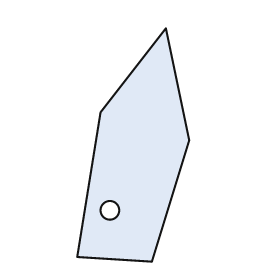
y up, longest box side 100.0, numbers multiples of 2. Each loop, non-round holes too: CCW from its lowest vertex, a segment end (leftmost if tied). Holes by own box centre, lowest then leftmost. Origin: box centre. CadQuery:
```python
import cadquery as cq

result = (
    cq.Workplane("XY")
    .moveTo(8.0, -50.0)
    .lineTo(24.0, 2.0)
    .lineTo(14.0, 50.0)
    .lineTo(-14.0, 14.0)
    .lineTo(-24.0, -48.0)
    .close()
    .moveTo(-10.0, -28.0)
    .circle(4.0)
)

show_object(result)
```